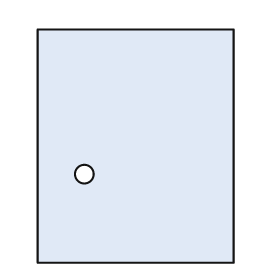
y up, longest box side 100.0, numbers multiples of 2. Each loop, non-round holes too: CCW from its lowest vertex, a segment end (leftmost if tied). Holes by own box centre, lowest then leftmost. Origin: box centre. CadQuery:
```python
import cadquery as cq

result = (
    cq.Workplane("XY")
    .moveTo(-42.0, -50.0)
    .lineTo(42.0, -50.0)
    .lineTo(42.0, 50.0)
    .lineTo(-42.0, 50.0)
    .close()
    .moveTo(-22.0, -12.0)
    .circle(4.0)
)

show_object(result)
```